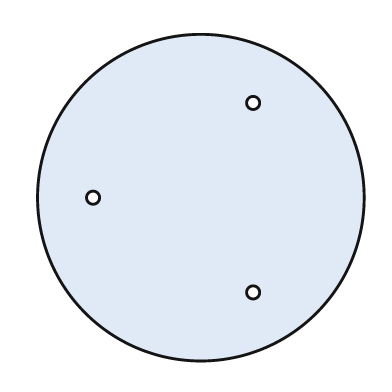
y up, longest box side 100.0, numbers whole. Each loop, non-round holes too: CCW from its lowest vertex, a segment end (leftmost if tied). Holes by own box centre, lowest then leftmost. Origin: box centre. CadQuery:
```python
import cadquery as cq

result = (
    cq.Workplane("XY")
    .moveTo(0.0, 0.0)
    .circle(50.0)
    .moveTo(16.0, -29.0)
    .circle(2.0)
    .moveTo(-33.0, 0.0)
    .circle(2.0)
    .moveTo(16.0, 29.0)
    .circle(2.0)
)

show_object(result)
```